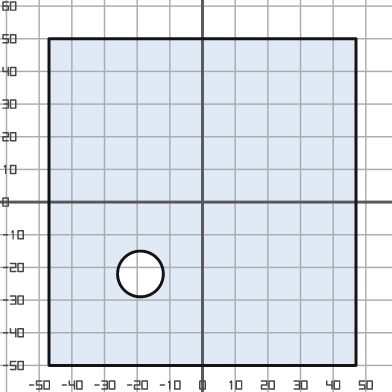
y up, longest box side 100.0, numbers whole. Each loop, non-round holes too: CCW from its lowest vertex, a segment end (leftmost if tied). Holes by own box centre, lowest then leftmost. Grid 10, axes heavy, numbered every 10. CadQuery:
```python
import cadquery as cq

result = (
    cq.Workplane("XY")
    .moveTo(-47.0, -50.0)
    .lineTo(47.0, -50.0)
    .lineTo(47.0, 50.0)
    .lineTo(-47.0, 50.0)
    .close()
    .moveTo(-19.0, -22.0)
    .circle(7.0)
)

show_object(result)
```